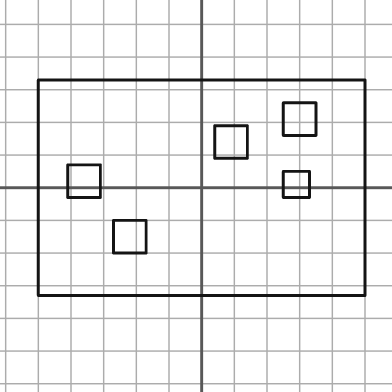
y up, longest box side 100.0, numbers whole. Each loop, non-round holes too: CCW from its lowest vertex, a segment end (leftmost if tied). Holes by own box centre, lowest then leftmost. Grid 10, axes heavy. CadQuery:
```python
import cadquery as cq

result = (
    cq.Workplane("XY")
    .moveTo(-50.0, -33.0)
    .lineTo(50.0, -33.0)
    .lineTo(50.0, 33.0)
    .lineTo(-50.0, 33.0)
    .close()
    .moveTo(-27.0, -20.0)
    .lineTo(-17.0, -20.0)
    .lineTo(-17.0, -10.0)
    .lineTo(-27.0, -10.0)
    .close()
    .moveTo(25.0, -3.0)
    .lineTo(33.0, -3.0)
    .lineTo(33.0, 5.0)
    .lineTo(25.0, 5.0)
    .close()
    .moveTo(-41.0, -3.0)
    .lineTo(-31.0, -3.0)
    .lineTo(-31.0, 7.0)
    .lineTo(-41.0, 7.0)
    .close()
    .moveTo(4.0, 9.0)
    .lineTo(14.0, 9.0)
    .lineTo(14.0, 19.0)
    .lineTo(4.0, 19.0)
    .close()
    .moveTo(25.0, 16.0)
    .lineTo(35.0, 16.0)
    .lineTo(35.0, 26.0)
    .lineTo(25.0, 26.0)
    .close()
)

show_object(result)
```